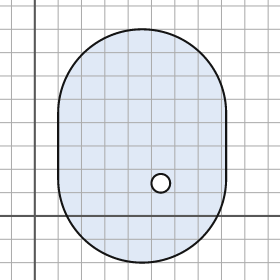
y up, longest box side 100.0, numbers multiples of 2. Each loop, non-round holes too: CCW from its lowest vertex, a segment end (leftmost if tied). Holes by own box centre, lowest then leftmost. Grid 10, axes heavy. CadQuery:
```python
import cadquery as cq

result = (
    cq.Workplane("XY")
    .moveTo(10.0, 16.0)
    .threePointArc((46.0, -20.0), (82.0, 16.0))
    .lineTo(82.0, 44.0)
    .threePointArc((46.0, 80.0), (10.0, 44.0))
    .close()
    .moveTo(54.0, 14.0)
    .circle(4.0)
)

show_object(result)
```